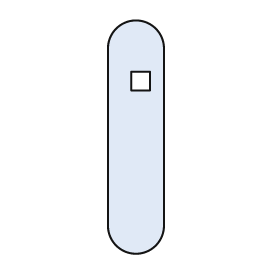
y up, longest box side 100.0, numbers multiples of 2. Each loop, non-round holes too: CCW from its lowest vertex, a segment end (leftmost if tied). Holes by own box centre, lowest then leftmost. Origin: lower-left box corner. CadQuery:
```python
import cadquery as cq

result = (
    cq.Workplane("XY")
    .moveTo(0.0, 12.0)
    .threePointArc((12.0, 0.0), (24.0, 12.0))
    .lineTo(24.0, 88.0)
    .threePointArc((12.0, 100.0), (0.0, 88.0))
    .close()
    .moveTo(10.0, 70.0)
    .lineTo(18.0, 70.0)
    .lineTo(18.0, 78.0)
    .lineTo(10.0, 78.0)
    .close()
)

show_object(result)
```